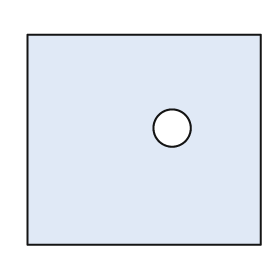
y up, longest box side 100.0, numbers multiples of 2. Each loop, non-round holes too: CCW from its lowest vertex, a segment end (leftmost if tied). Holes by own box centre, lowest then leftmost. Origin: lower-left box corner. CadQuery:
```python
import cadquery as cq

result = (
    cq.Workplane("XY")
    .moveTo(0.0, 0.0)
    .lineTo(100.0, 0.0)
    .lineTo(100.0, 90.0)
    .lineTo(0.0, 90.0)
    .close()
    .moveTo(62.0, 50.0)
    .circle(8.0)
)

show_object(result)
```